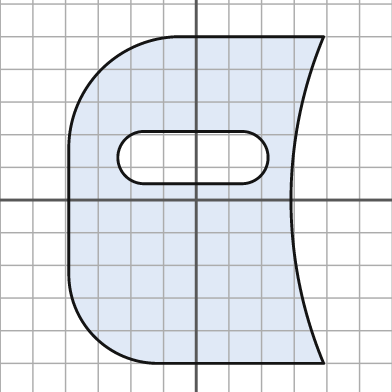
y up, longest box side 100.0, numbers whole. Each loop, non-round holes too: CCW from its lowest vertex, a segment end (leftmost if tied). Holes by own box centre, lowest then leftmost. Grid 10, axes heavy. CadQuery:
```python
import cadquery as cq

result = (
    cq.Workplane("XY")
    .moveTo(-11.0, -50.0)
    .lineTo(39.0, -50.0)
    .threePointArc((29.0, 0.0), (39.0, 50.0))
    .lineTo(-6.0, 50.0)
    .threePointArc((-29.0, 40.0), (-39.0, 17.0))
    .lineTo(-39.0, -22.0)
    .threePointArc((-31.0, -42.0), (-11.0, -50.0))
    .close()
    .moveTo(-16.0, 5.0)
    .lineTo(14.0, 5.0)
    .threePointArc((22.0, 13.0), (14.0, 21.0))
    .lineTo(-16.0, 21.0)
    .threePointArc((-24.0, 13.0), (-16.0, 5.0))
    .close()
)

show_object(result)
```